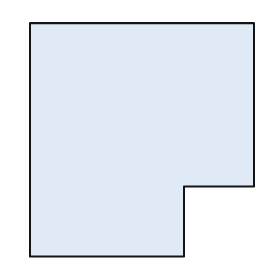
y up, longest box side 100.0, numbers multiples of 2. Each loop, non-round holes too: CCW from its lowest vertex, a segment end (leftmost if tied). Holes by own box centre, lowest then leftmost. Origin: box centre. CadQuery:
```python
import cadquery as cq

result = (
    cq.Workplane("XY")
    .moveTo(-48.0, -50.0)
    .lineTo(18.0, -50.0)
    .lineTo(18.0, -20.0)
    .lineTo(48.0, -20.0)
    .lineTo(48.0, 50.0)
    .lineTo(-48.0, 50.0)
    .close()
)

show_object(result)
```